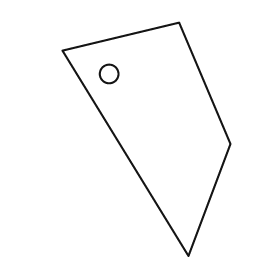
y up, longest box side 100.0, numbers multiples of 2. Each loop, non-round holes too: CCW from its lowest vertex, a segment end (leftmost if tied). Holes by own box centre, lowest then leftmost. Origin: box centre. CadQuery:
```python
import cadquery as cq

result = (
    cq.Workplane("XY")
    .moveTo(18.0, -50.0)
    .lineTo(36.0, -2.0)
    .lineTo(14.0, 50.0)
    .lineTo(-36.0, 38.0)
    .close()
    .moveTo(-16.0, 28.0)
    .circle(4.0)
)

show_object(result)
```